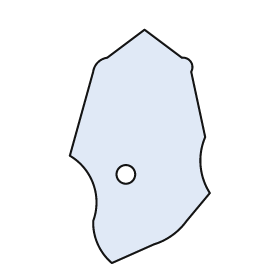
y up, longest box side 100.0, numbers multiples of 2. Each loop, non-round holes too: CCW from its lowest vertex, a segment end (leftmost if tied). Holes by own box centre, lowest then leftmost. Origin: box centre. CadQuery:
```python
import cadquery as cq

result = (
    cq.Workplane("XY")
    .moveTo(-12.0, -50.0)
    .lineTo(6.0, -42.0)
    .threePointArc((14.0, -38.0), (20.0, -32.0))
    .lineTo(30.0, -20.0)
    .threePointArc((26.0, -8.0), (28.0, 4.0))
    .lineTo(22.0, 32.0)
    .threePointArc((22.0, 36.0), (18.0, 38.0))
    .lineTo(2.0, 50.0)
    .lineTo(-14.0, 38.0)
    .threePointArc((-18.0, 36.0), (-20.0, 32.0))
    .lineTo(-30.0, -4.0)
    .threePointArc((-20.0, -16.0), (-20.0, -32.0))
    .threePointArc((-18.0, -42.0), (-12.0, -50.0))
    .close()
    .moveTo(-6.0, -12.0)
    .circle(4.0)
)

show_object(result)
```